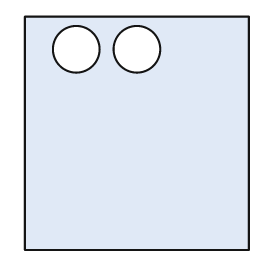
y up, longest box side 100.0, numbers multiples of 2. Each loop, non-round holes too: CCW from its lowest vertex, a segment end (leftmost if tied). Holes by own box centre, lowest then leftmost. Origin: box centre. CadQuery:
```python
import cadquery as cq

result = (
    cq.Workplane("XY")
    .moveTo(-48.0, -50.0)
    .lineTo(48.0, -50.0)
    .lineTo(48.0, 50.0)
    .lineTo(-48.0, 50.0)
    .close()
    .moveTo(-26.0, 36.0)
    .circle(10.0)
    .moveTo(0.0, 36.0)
    .circle(10.0)
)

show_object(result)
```